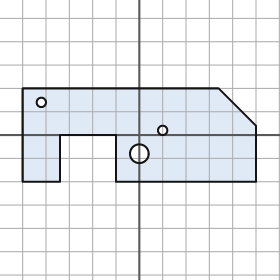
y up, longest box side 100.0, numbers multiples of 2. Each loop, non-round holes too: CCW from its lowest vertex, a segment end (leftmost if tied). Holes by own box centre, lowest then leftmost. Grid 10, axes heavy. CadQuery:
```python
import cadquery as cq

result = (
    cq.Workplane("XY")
    .moveTo(-50.0, -20.0)
    .lineTo(-34.0, -20.0)
    .lineTo(-34.0, 0.0)
    .lineTo(-10.0, 0.0)
    .lineTo(-10.0, -20.0)
    .lineTo(50.0, -20.0)
    .lineTo(50.0, 4.0)
    .lineTo(34.0, 20.0)
    .lineTo(-50.0, 20.0)
    .close()
    .moveTo(0.0, -8.0)
    .circle(4.0)
    .moveTo(10.0, 2.0)
    .circle(2.0)
    .moveTo(-42.0, 14.0)
    .circle(2.0)
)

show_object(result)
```